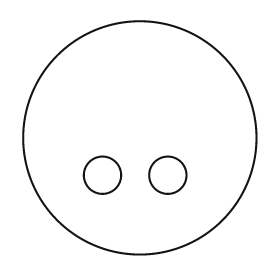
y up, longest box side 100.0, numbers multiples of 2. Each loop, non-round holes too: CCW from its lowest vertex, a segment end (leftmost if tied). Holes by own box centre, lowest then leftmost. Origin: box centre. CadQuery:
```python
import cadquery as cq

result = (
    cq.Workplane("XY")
    .moveTo(0.0, 0.0)
    .circle(50.0)
    .moveTo(-16.0, -16.0)
    .circle(8.0)
    .moveTo(12.0, -16.0)
    .circle(8.0)
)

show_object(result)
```